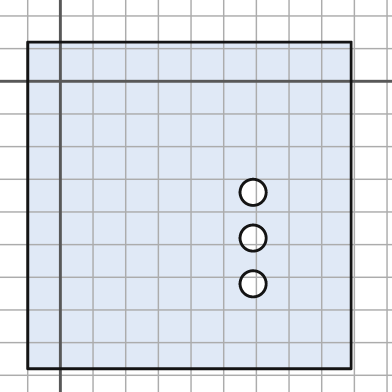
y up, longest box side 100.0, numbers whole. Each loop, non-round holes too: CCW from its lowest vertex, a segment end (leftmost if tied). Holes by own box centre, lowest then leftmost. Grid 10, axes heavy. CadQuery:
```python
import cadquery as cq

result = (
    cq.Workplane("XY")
    .moveTo(-10.0, -88.0)
    .lineTo(89.0, -88.0)
    .lineTo(89.0, 12.0)
    .lineTo(-10.0, 12.0)
    .close()
    .moveTo(59.0, -62.0)
    .circle(4.0)
    .moveTo(59.0, -48.0)
    .circle(4.0)
    .moveTo(59.0, -34.0)
    .circle(4.0)
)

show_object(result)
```